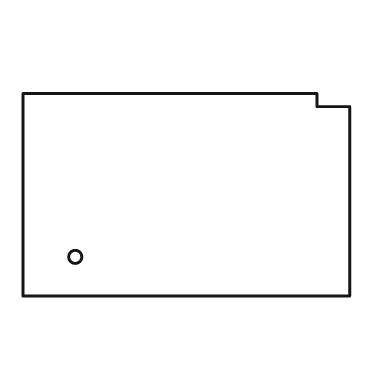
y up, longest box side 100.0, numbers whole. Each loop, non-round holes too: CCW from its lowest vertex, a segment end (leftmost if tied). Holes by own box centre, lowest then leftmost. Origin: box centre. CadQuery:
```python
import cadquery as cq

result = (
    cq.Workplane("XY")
    .moveTo(-50.0, -31.0)
    .lineTo(50.0, -31.0)
    .lineTo(50.0, 27.0)
    .lineTo(40.0, 27.0)
    .lineTo(40.0, 31.0)
    .lineTo(-50.0, 31.0)
    .close()
    .moveTo(-34.0, -19.0)
    .circle(2.0)
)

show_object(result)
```